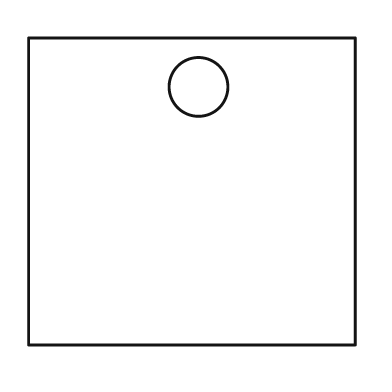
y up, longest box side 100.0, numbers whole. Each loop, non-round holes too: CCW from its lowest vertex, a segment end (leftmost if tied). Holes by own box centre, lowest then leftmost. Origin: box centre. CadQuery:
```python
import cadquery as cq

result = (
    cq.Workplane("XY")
    .moveTo(-50.0, -47.0)
    .lineTo(50.0, -47.0)
    .lineTo(50.0, 47.0)
    .lineTo(-50.0, 47.0)
    .close()
    .moveTo(2.0, 32.0)
    .circle(9.0)
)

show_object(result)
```